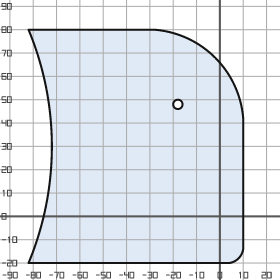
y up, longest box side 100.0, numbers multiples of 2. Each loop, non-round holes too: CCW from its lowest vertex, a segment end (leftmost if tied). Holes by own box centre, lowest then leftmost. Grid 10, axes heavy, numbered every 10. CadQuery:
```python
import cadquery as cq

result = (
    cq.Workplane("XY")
    .moveTo(-82.0, -20.0)
    .lineTo(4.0, -20.0)
    .threePointArc((8.0, -18.0), (10.0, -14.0))
    .lineTo(10.0, 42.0)
    .threePointArc((-2.0, 68.0), (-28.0, 80.0))
    .lineTo(-82.0, 80.0)
    .threePointArc((-72.0, 30.0), (-82.0, -20.0))
    .close()
    .moveTo(-18.0, 48.0)
    .circle(2.0)
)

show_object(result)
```